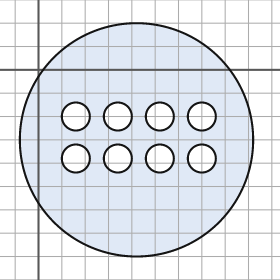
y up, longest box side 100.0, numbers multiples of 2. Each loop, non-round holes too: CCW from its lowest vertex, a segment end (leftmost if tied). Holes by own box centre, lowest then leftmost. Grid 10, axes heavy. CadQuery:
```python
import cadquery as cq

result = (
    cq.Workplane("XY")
    .moveTo(42.0, -30.0)
    .circle(50.0)
    .moveTo(16.0, -38.0)
    .circle(6.0)
    .moveTo(34.0, -38.0)
    .circle(6.0)
    .moveTo(52.0, -38.0)
    .circle(6.0)
    .moveTo(70.0, -38.0)
    .circle(6.0)
    .moveTo(16.0, -20.0)
    .circle(6.0)
    .moveTo(34.0, -20.0)
    .circle(6.0)
    .moveTo(52.0, -20.0)
    .circle(6.0)
    .moveTo(70.0, -20.0)
    .circle(6.0)
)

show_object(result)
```